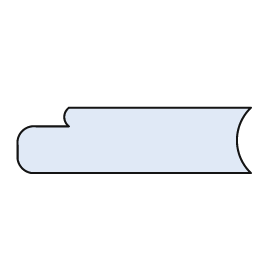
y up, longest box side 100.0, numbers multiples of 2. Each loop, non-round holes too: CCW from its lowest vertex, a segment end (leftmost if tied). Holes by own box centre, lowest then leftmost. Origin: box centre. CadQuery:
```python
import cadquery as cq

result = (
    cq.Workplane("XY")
    .moveTo(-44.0, -14.0)
    .lineTo(50.0, -14.0)
    .threePointArc((44.0, 0.0), (50.0, 14.0))
    .lineTo(-28.0, 14.0)
    .threePointArc((-30.0, 10.0), (-28.0, 6.0))
    .lineTo(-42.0, 6.0)
    .threePointArc((-48.0, 4.0), (-50.0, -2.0))
    .lineTo(-50.0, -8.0)
    .threePointArc((-48.0, -12.0), (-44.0, -14.0))
    .close()
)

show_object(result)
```